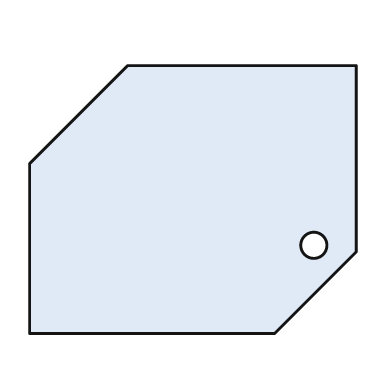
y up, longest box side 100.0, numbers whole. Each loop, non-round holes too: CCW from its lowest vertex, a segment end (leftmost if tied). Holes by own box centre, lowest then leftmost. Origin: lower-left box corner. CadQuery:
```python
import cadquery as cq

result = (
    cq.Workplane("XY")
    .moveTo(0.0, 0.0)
    .lineTo(75.0, 0.0)
    .lineTo(100.0, 25.0)
    .lineTo(100.0, 82.0)
    .lineTo(30.0, 82.0)
    .lineTo(0.0, 52.0)
    .close()
    .moveTo(87.0, 27.0)
    .circle(4.0)
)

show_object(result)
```